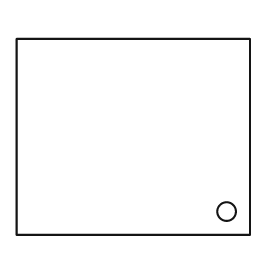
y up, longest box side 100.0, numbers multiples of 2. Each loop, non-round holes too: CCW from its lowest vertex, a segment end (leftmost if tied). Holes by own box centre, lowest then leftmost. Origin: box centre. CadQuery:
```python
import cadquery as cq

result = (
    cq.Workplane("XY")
    .moveTo(-50.0, -42.0)
    .lineTo(50.0, -42.0)
    .lineTo(50.0, 42.0)
    .lineTo(-50.0, 42.0)
    .close()
    .moveTo(40.0, -32.0)
    .circle(4.0)
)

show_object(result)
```